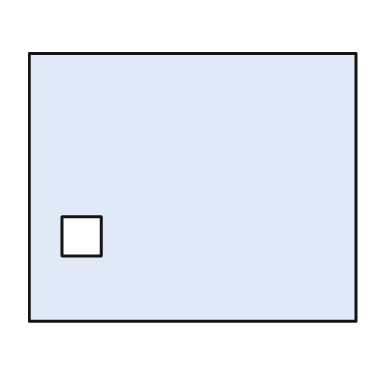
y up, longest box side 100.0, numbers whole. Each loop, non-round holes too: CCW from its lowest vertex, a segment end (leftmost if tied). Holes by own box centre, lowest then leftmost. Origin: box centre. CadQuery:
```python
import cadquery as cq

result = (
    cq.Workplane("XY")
    .moveTo(-50.0, -41.0)
    .lineTo(50.0, -41.0)
    .lineTo(50.0, 41.0)
    .lineTo(-50.0, 41.0)
    .close()
    .moveTo(-40.0, -21.0)
    .lineTo(-28.0, -21.0)
    .lineTo(-28.0, -9.0)
    .lineTo(-40.0, -9.0)
    .close()
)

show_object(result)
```